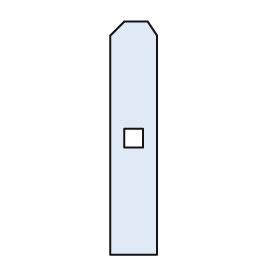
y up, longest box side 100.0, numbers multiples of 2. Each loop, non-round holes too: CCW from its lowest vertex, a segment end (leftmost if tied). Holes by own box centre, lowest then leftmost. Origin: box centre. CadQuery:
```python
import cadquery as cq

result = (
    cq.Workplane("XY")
    .moveTo(-10.0, -50.0)
    .lineTo(10.0, -50.0)
    .lineTo(10.0, 44.0)
    .lineTo(6.0, 50.0)
    .lineTo(-4.0, 50.0)
    .lineTo(-10.0, 44.0)
    .close()
    .moveTo(-4.0, -4.0)
    .lineTo(4.0, -4.0)
    .lineTo(4.0, 4.0)
    .lineTo(-4.0, 4.0)
    .close()
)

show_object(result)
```